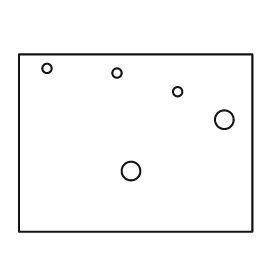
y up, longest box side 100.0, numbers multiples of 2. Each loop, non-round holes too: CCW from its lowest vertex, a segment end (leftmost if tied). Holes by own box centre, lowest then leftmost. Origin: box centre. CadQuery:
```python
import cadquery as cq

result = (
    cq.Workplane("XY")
    .moveTo(-50.0, -38.0)
    .lineTo(50.0, -38.0)
    .lineTo(50.0, 38.0)
    .lineTo(-50.0, 38.0)
    .close()
    .moveTo(-2.0, -12.0)
    .circle(4.0)
    .moveTo(38.0, 10.0)
    .circle(4.0)
    .moveTo(18.0, 22.0)
    .circle(2.0)
    .moveTo(-8.0, 30.0)
    .circle(2.0)
    .moveTo(-38.0, 32.0)
    .circle(2.0)
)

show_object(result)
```